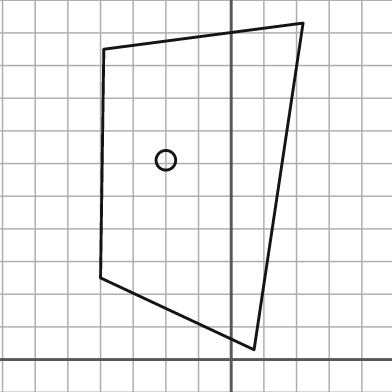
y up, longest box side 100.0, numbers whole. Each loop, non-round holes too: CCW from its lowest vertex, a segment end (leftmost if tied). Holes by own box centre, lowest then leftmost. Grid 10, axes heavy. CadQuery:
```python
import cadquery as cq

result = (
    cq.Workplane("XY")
    .moveTo(7.0, 3.0)
    .lineTo(22.0, 103.0)
    .lineTo(-39.0, 95.0)
    .lineTo(-40.0, 25.0)
    .close()
    .moveTo(-20.0, 61.0)
    .circle(3.0)
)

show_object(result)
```